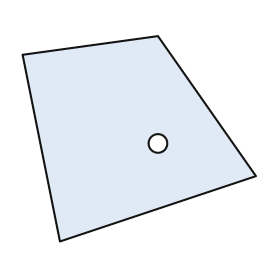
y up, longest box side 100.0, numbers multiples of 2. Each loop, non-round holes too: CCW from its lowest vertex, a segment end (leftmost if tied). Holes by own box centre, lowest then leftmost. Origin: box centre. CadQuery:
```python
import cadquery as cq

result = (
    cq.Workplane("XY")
    .moveTo(-34.0, -44.0)
    .lineTo(50.0, -16.0)
    .lineTo(8.0, 44.0)
    .lineTo(-50.0, 36.0)
    .close()
    .moveTo(8.0, -2.0)
    .circle(4.0)
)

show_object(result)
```